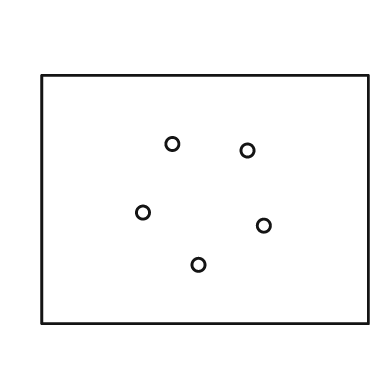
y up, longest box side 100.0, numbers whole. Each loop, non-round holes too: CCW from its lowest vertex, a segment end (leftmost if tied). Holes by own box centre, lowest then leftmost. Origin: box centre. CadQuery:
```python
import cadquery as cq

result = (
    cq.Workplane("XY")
    .moveTo(-50.0, -38.0)
    .lineTo(50.0, -38.0)
    .lineTo(50.0, 38.0)
    .lineTo(-50.0, 38.0)
    .close()
    .moveTo(-2.0, -20.0)
    .circle(2.0)
    .moveTo(18.0, -8.0)
    .circle(2.0)
    .moveTo(-19.0, -4.0)
    .circle(2.0)
    .moveTo(13.0, 15.0)
    .circle(2.0)
    .moveTo(-10.0, 17.0)
    .circle(2.0)
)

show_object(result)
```